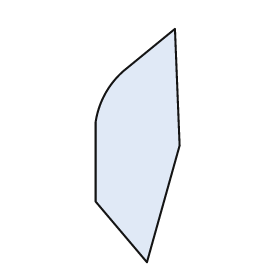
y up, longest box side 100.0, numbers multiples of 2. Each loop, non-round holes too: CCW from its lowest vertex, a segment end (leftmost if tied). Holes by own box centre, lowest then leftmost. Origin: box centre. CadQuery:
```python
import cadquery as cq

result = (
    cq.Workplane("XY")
    .moveTo(4.0, -50.0)
    .lineTo(18.0, 0.0)
    .lineTo(16.0, 50.0)
    .lineTo(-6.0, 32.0)
    .threePointArc((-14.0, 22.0), (-18.0, 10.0))
    .lineTo(-18.0, -24.0)
    .close()
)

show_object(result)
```